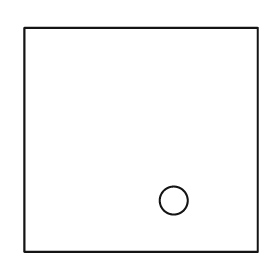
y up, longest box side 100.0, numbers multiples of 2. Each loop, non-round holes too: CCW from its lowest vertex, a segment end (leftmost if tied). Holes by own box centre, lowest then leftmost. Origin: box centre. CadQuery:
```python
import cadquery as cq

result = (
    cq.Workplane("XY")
    .moveTo(-50.0, -48.0)
    .lineTo(50.0, -48.0)
    .lineTo(50.0, 48.0)
    .lineTo(-50.0, 48.0)
    .close()
    .moveTo(14.0, -26.0)
    .circle(6.0)
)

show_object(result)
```